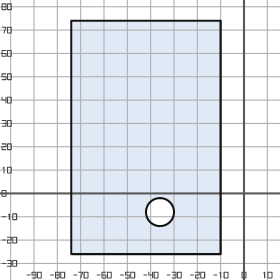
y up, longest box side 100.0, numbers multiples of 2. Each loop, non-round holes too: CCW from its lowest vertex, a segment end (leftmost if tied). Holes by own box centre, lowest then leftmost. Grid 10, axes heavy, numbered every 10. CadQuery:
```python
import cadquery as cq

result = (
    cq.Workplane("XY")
    .moveTo(-74.0, -26.0)
    .lineTo(-10.0, -26.0)
    .lineTo(-10.0, 74.0)
    .lineTo(-74.0, 74.0)
    .close()
    .moveTo(-36.0, -8.0)
    .circle(6.0)
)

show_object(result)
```